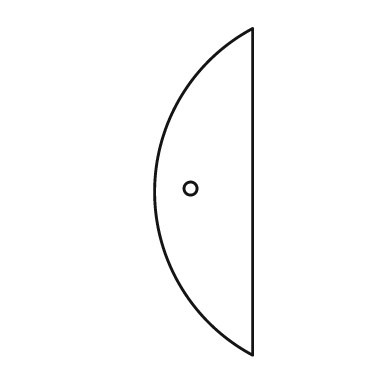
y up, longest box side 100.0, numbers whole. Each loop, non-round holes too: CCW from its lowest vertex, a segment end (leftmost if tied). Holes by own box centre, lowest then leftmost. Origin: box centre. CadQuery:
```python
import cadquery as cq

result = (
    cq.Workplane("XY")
    .moveTo(15.0, -50.0)
    .lineTo(15.0, 50.0)
    .threePointArc((-15.0, 0.0), (15.0, -50.0))
    .close()
    .moveTo(-4.0, 1.0)
    .circle(2.0)
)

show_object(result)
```